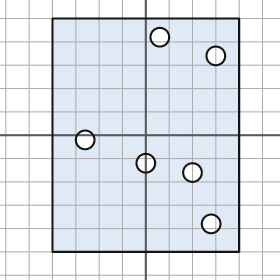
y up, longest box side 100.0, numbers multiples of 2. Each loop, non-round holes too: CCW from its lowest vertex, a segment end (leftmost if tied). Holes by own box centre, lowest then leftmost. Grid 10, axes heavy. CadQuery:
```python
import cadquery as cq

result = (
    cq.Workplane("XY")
    .moveTo(-40.0, -50.0)
    .lineTo(40.0, -50.0)
    .lineTo(40.0, 50.0)
    .lineTo(-40.0, 50.0)
    .close()
    .moveTo(28.0, -38.0)
    .circle(4.0)
    .moveTo(20.0, -16.0)
    .circle(4.0)
    .moveTo(0.0, -12.0)
    .circle(4.0)
    .moveTo(-26.0, -2.0)
    .circle(4.0)
    .moveTo(30.0, 34.0)
    .circle(4.0)
    .moveTo(6.0, 42.0)
    .circle(4.0)
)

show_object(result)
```